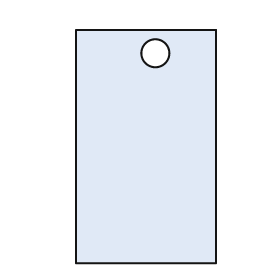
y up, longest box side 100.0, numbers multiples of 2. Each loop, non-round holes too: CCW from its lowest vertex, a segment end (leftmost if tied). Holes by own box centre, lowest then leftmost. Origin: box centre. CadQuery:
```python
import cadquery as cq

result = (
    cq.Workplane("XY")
    .moveTo(-30.0, -50.0)
    .lineTo(30.0, -50.0)
    .lineTo(30.0, 50.0)
    .lineTo(-30.0, 50.0)
    .close()
    .moveTo(4.0, 40.0)
    .circle(6.0)
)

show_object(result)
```